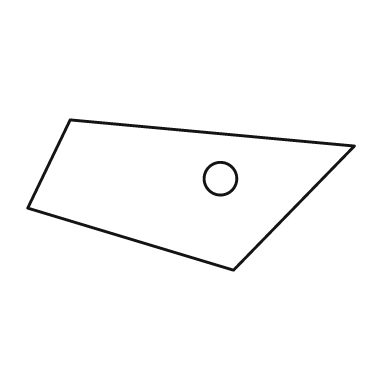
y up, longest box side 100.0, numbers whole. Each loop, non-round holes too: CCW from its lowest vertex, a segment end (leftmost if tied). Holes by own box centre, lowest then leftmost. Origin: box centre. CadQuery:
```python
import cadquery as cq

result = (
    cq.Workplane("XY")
    .moveTo(13.0, -23.0)
    .lineTo(50.0, 15.0)
    .lineTo(-37.0, 23.0)
    .lineTo(-50.0, -4.0)
    .close()
    .moveTo(9.0, 5.0)
    .circle(5.0)
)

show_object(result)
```